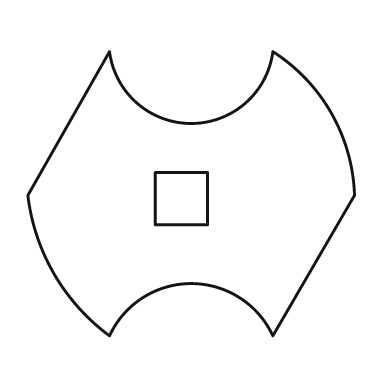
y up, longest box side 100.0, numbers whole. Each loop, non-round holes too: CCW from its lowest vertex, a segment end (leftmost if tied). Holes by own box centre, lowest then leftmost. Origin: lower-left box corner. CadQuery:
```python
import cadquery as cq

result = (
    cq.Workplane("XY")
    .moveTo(25.0, 0.0)
    .threePointArc((50.0, 16.0), (75.0, 0.0))
    .lineTo(100.0, 43.0)
    .threePointArc((93.0, 68.0), (75.0, 87.0))
    .threePointArc((50.0, 65.0), (25.0, 87.0))
    .lineTo(0.0, 43.0)
    .threePointArc((8.0, 19.0), (25.0, 0.0))
    .close()
    .moveTo(39.0, 34.0)
    .lineTo(55.0, 34.0)
    .lineTo(55.0, 50.0)
    .lineTo(39.0, 50.0)
    .close()
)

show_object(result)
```